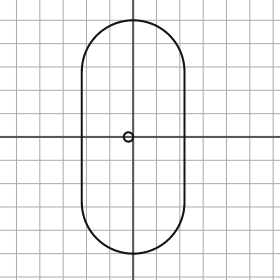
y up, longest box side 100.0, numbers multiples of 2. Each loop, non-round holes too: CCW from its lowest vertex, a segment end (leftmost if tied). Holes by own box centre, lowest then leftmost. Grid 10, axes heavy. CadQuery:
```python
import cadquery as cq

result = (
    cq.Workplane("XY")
    .moveTo(-22.0, -28.0)
    .threePointArc((0.0, -50.0), (22.0, -28.0))
    .lineTo(22.0, 28.0)
    .threePointArc((0.0, 50.0), (-22.0, 28.0))
    .close()
    .moveTo(-2.0, 0.0)
    .circle(2.0)
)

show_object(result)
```